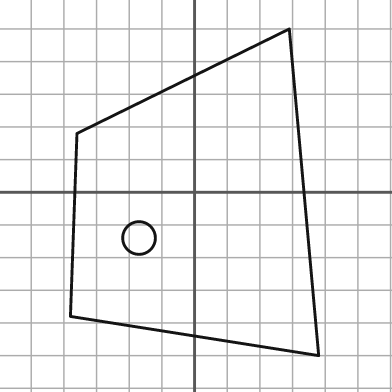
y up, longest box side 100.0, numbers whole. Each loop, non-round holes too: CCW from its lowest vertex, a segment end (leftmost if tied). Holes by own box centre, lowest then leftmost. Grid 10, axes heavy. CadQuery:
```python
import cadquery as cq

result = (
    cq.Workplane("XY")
    .moveTo(38.0, -50.0)
    .lineTo(29.0, 50.0)
    .lineTo(-36.0, 18.0)
    .lineTo(-38.0, -38.0)
    .close()
    .moveTo(-17.0, -14.0)
    .circle(5.0)
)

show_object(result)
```